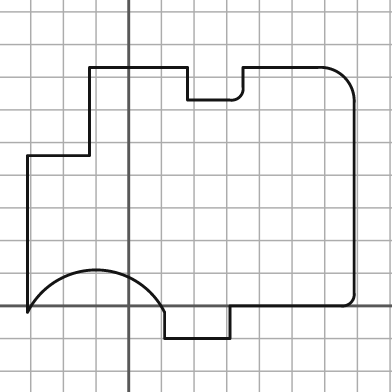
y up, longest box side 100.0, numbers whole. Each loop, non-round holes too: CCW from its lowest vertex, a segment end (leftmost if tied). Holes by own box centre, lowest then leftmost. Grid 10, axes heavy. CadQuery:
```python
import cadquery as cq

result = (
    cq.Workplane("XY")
    .moveTo(11.0, -10.0)
    .lineTo(31.0, -10.0)
    .lineTo(31.0, 0.0)
    .lineTo(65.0, 0.0)
    .threePointArc((68.0, 1.0), (69.0, 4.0))
    .lineTo(69.0, 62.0)
    .threePointArc((66.0, 70.0), (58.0, 73.0))
    .lineTo(35.0, 73.0)
    .lineTo(35.0, 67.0)
    .threePointArc((34.0, 64.0), (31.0, 63.0))
    .lineTo(18.0, 63.0)
    .lineTo(18.0, 73.0)
    .lineTo(-12.0, 73.0)
    .lineTo(-12.0, 46.0)
    .lineTo(-31.0, 46.0)
    .lineTo(-31.0, -2.0)
    .threePointArc((-10.0, 11.0), (11.0, -2.0))
    .close()
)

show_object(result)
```